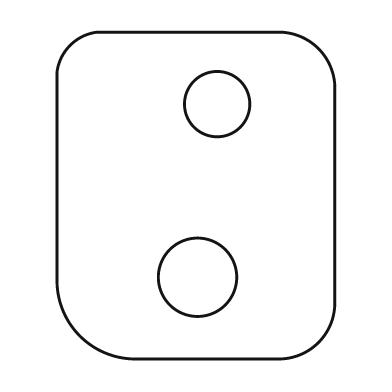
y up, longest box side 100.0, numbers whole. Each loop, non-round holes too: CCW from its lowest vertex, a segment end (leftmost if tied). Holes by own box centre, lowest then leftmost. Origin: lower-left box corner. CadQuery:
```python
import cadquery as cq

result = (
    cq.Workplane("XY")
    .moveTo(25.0, 0.0)
    .lineTo(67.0, 0.0)
    .threePointArc((80.0, 5.0), (85.0, 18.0))
    .lineTo(85.0, 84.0)
    .threePointArc((80.0, 95.0), (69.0, 100.0))
    .lineTo(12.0, 100.0)
    .threePointArc((4.0, 96.0), (0.0, 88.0))
    .lineTo(0.0, 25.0)
    .threePointArc((7.0, 7.0), (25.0, 0.0))
    .close()
    .moveTo(43.0, 25.0)
    .circle(12.0)
    .moveTo(49.0, 78.0)
    .circle(10.0)
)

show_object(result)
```